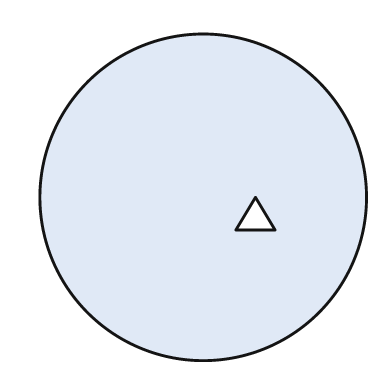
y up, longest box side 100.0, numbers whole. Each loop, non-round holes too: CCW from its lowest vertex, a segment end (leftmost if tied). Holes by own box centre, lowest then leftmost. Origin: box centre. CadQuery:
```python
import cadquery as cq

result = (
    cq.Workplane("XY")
    .moveTo(0.0, 0.0)
    .circle(50.0)
    .moveTo(10.0, -10.0)
    .lineTo(22.0, -10.0)
    .lineTo(16.0, 0.0)
    .close()
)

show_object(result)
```